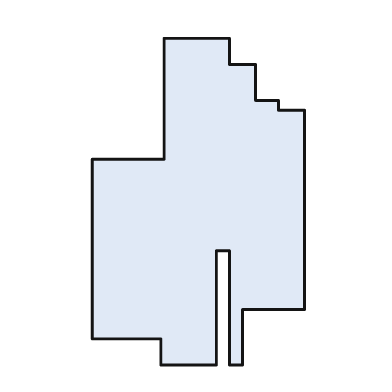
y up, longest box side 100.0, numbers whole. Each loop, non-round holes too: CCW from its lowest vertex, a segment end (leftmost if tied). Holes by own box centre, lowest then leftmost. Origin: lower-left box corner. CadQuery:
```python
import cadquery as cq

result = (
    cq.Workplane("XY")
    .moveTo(21.0, 0.0)
    .lineTo(38.0, 0.0)
    .lineTo(38.0, 35.0)
    .lineTo(42.0, 35.0)
    .lineTo(42.0, 0.0)
    .lineTo(46.0, 0.0)
    .lineTo(46.0, 17.0)
    .lineTo(65.0, 17.0)
    .lineTo(65.0, 78.0)
    .lineTo(57.0, 78.0)
    .lineTo(57.0, 81.0)
    .lineTo(50.0, 81.0)
    .lineTo(50.0, 92.0)
    .lineTo(42.0, 92.0)
    .lineTo(42.0, 100.0)
    .lineTo(22.0, 100.0)
    .lineTo(22.0, 63.0)
    .lineTo(0.0, 63.0)
    .lineTo(0.0, 8.0)
    .lineTo(21.0, 8.0)
    .close()
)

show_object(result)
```